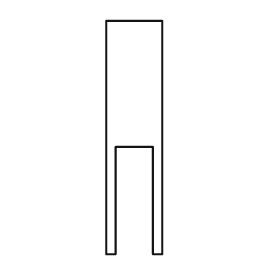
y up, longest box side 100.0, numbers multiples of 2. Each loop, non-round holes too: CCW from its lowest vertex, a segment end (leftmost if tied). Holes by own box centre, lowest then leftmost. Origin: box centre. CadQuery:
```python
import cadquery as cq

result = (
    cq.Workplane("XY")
    .moveTo(-12.0, -50.0)
    .lineTo(-8.0, -50.0)
    .lineTo(-8.0, -4.0)
    .lineTo(8.0, -4.0)
    .lineTo(8.0, -50.0)
    .lineTo(12.0, -50.0)
    .lineTo(12.0, 50.0)
    .lineTo(-12.0, 50.0)
    .close()
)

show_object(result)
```